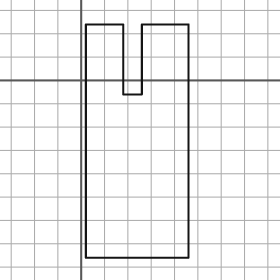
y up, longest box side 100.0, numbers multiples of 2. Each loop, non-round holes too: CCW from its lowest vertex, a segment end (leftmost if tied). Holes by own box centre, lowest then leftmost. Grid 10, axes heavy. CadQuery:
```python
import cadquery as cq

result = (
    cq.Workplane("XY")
    .moveTo(2.0, -76.0)
    .lineTo(46.0, -76.0)
    .lineTo(46.0, 24.0)
    .lineTo(26.0, 24.0)
    .lineTo(26.0, -6.0)
    .lineTo(18.0, -6.0)
    .lineTo(18.0, 24.0)
    .lineTo(2.0, 24.0)
    .close()
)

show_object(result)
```